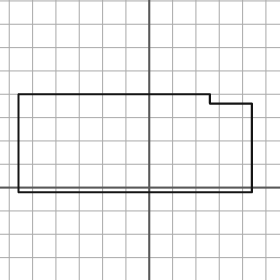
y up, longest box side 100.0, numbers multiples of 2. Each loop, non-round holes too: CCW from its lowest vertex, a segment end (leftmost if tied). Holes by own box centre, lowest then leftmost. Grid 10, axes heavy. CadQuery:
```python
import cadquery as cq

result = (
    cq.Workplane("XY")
    .moveTo(-56.0, -2.0)
    .lineTo(44.0, -2.0)
    .lineTo(44.0, 36.0)
    .lineTo(26.0, 36.0)
    .lineTo(26.0, 40.0)
    .lineTo(-56.0, 40.0)
    .close()
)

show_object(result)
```